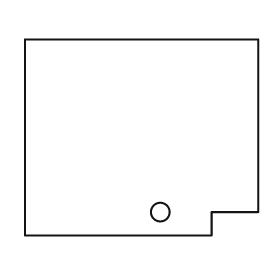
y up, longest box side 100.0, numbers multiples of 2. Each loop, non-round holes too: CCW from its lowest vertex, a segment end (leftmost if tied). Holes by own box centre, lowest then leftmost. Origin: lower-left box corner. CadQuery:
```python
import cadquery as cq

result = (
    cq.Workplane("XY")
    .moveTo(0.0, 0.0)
    .lineTo(80.0, 0.0)
    .lineTo(80.0, 10.0)
    .lineTo(100.0, 10.0)
    .lineTo(100.0, 84.0)
    .lineTo(0.0, 84.0)
    .close()
    .moveTo(58.0, 10.0)
    .circle(4.0)
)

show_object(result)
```